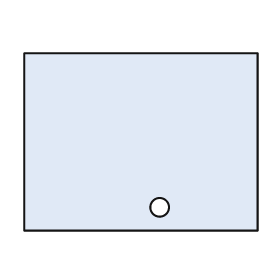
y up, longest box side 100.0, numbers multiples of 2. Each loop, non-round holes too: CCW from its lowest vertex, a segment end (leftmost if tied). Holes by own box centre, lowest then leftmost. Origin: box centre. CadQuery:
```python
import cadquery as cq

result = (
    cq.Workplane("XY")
    .moveTo(-50.0, -38.0)
    .lineTo(50.0, -38.0)
    .lineTo(50.0, 38.0)
    .lineTo(-50.0, 38.0)
    .close()
    .moveTo(8.0, -28.0)
    .circle(4.0)
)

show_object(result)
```